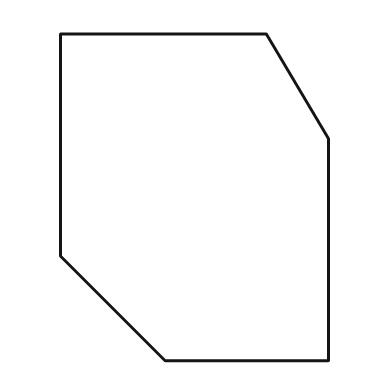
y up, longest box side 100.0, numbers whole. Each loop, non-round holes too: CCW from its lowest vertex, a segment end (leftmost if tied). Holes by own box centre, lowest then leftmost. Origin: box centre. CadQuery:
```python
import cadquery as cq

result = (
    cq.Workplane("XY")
    .moveTo(-9.0, -50.0)
    .lineTo(41.0, -50.0)
    .lineTo(41.0, 18.0)
    .lineTo(22.0, 50.0)
    .lineTo(-41.0, 50.0)
    .lineTo(-41.0, -18.0)
    .close()
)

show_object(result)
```